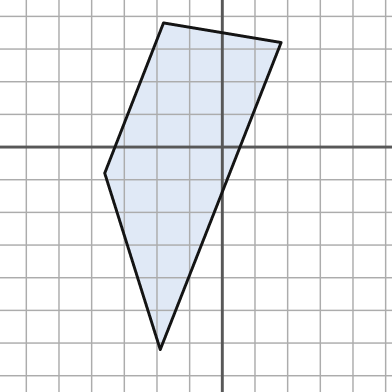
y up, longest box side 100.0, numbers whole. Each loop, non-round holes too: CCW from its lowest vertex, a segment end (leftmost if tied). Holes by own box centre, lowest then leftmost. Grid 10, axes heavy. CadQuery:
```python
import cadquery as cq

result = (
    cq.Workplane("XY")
    .moveTo(-19.0, -62.0)
    .lineTo(18.0, 32.0)
    .lineTo(-18.0, 38.0)
    .lineTo(-36.0, -8.0)
    .close()
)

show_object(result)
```